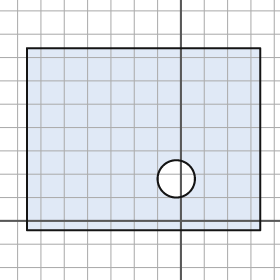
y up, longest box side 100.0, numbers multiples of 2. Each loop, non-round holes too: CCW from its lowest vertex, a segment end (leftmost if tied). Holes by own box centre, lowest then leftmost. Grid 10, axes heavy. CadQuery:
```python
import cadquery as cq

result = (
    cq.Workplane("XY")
    .moveTo(-66.0, -4.0)
    .lineTo(34.0, -4.0)
    .lineTo(34.0, 74.0)
    .lineTo(-66.0, 74.0)
    .close()
    .moveTo(-2.0, 18.0)
    .circle(8.0)
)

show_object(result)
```